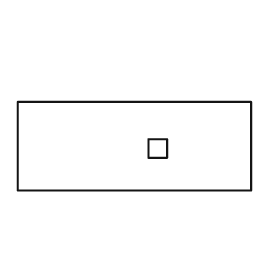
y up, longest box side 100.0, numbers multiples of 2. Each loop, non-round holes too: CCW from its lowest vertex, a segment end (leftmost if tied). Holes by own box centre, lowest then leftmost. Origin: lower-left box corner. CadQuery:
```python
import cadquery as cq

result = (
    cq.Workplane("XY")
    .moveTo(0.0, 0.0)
    .lineTo(100.0, 0.0)
    .lineTo(100.0, 38.0)
    .lineTo(0.0, 38.0)
    .close()
    .moveTo(56.0, 14.0)
    .lineTo(64.0, 14.0)
    .lineTo(64.0, 22.0)
    .lineTo(56.0, 22.0)
    .close()
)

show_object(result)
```